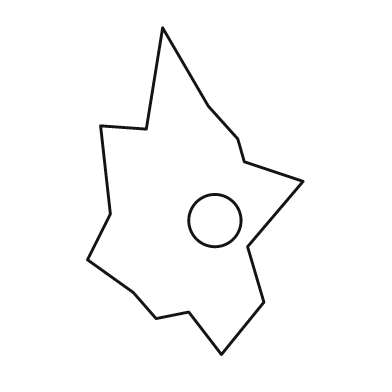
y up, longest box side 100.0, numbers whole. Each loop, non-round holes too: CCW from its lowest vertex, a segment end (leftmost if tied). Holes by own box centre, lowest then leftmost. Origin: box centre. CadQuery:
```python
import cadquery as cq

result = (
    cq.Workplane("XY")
    .moveTo(8.0, -50.0)
    .lineTo(21.0, -34.0)
    .lineTo(16.0, -17.0)
    .lineTo(33.0, 3.0)
    .lineTo(15.0, 9.0)
    .lineTo(13.0, 16.0)
    .lineTo(4.0, 26.0)
    .lineTo(-10.0, 50.0)
    .lineTo(-15.0, 19.0)
    .lineTo(-29.0, 20.0)
    .lineTo(-26.0, -7.0)
    .lineTo(-33.0, -21.0)
    .lineTo(-19.0, -31.0)
    .lineTo(-12.0, -39.0)
    .lineTo(-2.0, -37.0)
    .close()
    .moveTo(6.0, -9.0)
    .circle(8.0)
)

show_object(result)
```